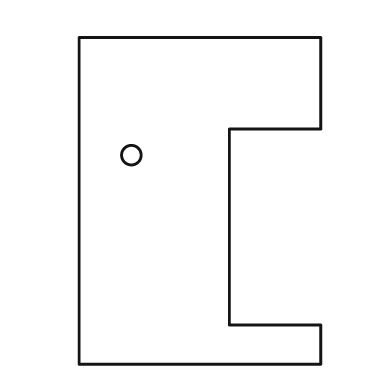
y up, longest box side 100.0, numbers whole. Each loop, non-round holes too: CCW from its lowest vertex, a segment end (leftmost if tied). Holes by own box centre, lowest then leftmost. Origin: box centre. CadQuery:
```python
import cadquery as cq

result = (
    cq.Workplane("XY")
    .moveTo(-37.0, -50.0)
    .lineTo(37.0, -50.0)
    .lineTo(37.0, -38.0)
    .lineTo(9.0, -38.0)
    .lineTo(9.0, 22.0)
    .lineTo(37.0, 22.0)
    .lineTo(37.0, 50.0)
    .lineTo(-37.0, 50.0)
    .close()
    .moveTo(-21.0, 14.0)
    .circle(3.0)
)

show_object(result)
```